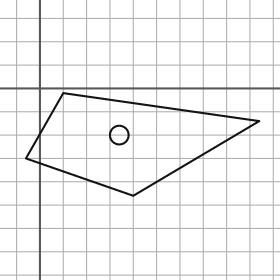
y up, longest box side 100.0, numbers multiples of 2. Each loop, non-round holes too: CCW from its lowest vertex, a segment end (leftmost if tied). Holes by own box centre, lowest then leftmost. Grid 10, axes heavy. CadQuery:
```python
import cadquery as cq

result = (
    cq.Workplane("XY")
    .moveTo(40.0, -46.0)
    .lineTo(94.0, -14.0)
    .lineTo(10.0, -2.0)
    .lineTo(-6.0, -30.0)
    .close()
    .moveTo(34.0, -20.0)
    .circle(4.0)
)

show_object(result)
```